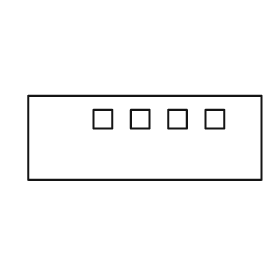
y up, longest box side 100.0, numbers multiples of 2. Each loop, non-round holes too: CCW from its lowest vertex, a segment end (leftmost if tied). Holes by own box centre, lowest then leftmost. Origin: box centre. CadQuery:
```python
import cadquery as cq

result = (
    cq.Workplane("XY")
    .moveTo(-50.0, -18.0)
    .lineTo(50.0, -18.0)
    .lineTo(50.0, 18.0)
    .lineTo(-50.0, 18.0)
    .close()
    .moveTo(-22.0, 4.0)
    .lineTo(-14.0, 4.0)
    .lineTo(-14.0, 12.0)
    .lineTo(-22.0, 12.0)
    .close()
    .moveTo(-6.0, 4.0)
    .lineTo(2.0, 4.0)
    .lineTo(2.0, 12.0)
    .lineTo(-6.0, 12.0)
    .close()
    .moveTo(10.0, 4.0)
    .lineTo(18.0, 4.0)
    .lineTo(18.0, 12.0)
    .lineTo(10.0, 12.0)
    .close()
    .moveTo(26.0, 4.0)
    .lineTo(34.0, 4.0)
    .lineTo(34.0, 12.0)
    .lineTo(26.0, 12.0)
    .close()
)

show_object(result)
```